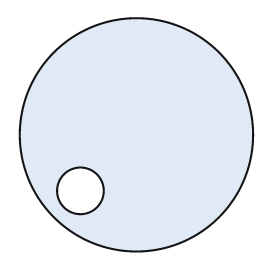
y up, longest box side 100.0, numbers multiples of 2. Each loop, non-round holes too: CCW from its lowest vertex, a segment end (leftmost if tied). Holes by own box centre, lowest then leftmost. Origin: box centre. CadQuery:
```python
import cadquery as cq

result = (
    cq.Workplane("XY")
    .moveTo(0.0, 0.0)
    .circle(50.0)
    .moveTo(-24.0, -24.0)
    .circle(10.0)
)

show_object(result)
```